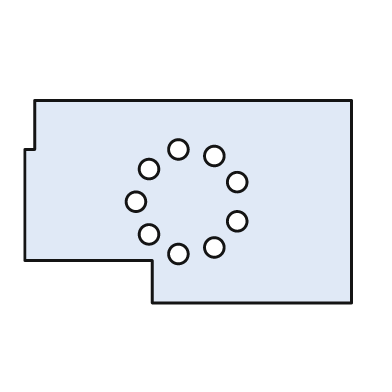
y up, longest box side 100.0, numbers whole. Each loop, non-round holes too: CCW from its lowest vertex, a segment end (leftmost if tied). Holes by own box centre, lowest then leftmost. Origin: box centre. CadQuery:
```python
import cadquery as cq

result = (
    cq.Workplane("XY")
    .moveTo(-11.0, -31.0)
    .lineTo(50.0, -31.0)
    .lineTo(50.0, 31.0)
    .lineTo(-47.0, 31.0)
    .lineTo(-47.0, 16.0)
    .lineTo(-50.0, 16.0)
    .lineTo(-50.0, -18.0)
    .lineTo(-11.0, -18.0)
    .close()
    .moveTo(-3.0, -16.0)
    .circle(3.0)
    .moveTo(8.0, -14.0)
    .circle(3.0)
    .moveTo(-12.0, -10.0)
    .circle(3.0)
    .moveTo(15.0, -6.0)
    .circle(3.0)
    .moveTo(-16.0, 0.0)
    .circle(3.0)
    .moveTo(15.0, 6.0)
    .circle(3.0)
    .moveTo(-12.0, 10.0)
    .circle(3.0)
    .moveTo(8.0, 14.0)
    .circle(3.0)
    .moveTo(-3.0, 16.0)
    .circle(3.0)
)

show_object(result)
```